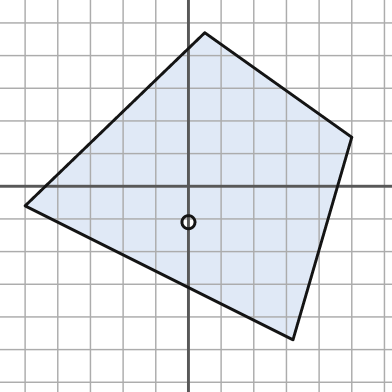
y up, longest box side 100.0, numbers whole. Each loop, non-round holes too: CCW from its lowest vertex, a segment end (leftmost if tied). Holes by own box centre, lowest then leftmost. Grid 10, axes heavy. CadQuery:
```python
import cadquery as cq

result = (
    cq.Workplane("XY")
    .moveTo(32.0, -47.0)
    .lineTo(50.0, 15.0)
    .lineTo(5.0, 47.0)
    .lineTo(-50.0, -6.0)
    .close()
    .moveTo(0.0, -11.0)
    .circle(2.0)
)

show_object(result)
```